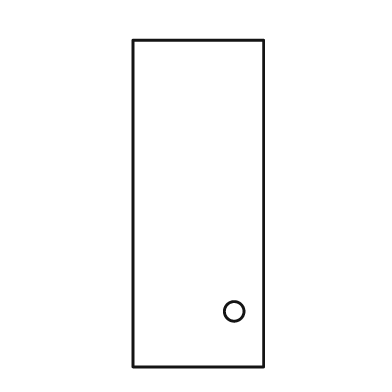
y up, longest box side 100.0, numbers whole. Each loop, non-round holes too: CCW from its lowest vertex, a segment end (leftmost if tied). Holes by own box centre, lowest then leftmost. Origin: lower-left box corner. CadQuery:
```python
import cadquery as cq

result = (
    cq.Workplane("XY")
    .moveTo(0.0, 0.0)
    .lineTo(40.0, 0.0)
    .lineTo(40.0, 100.0)
    .lineTo(0.0, 100.0)
    .close()
    .moveTo(31.0, 17.0)
    .circle(3.0)
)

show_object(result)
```